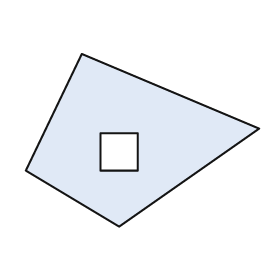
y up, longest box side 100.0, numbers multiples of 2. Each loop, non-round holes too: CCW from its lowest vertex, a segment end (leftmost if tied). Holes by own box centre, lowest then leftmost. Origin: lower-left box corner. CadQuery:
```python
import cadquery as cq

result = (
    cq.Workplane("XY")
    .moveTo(40.0, 0.0)
    .lineTo(100.0, 42.0)
    .lineTo(24.0, 74.0)
    .lineTo(0.0, 24.0)
    .close()
    .moveTo(32.0, 24.0)
    .lineTo(48.0, 24.0)
    .lineTo(48.0, 40.0)
    .lineTo(32.0, 40.0)
    .close()
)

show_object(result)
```